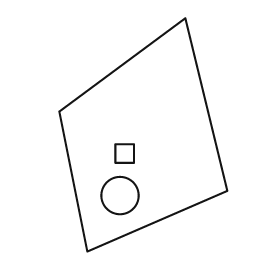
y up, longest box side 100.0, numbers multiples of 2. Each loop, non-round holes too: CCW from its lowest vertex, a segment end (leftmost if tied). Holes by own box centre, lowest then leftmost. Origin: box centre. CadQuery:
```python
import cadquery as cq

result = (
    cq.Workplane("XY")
    .moveTo(-24.0, -50.0)
    .lineTo(36.0, -24.0)
    .lineTo(18.0, 50.0)
    .lineTo(-36.0, 10.0)
    .close()
    .moveTo(-10.0, -26.0)
    .circle(8.0)
    .moveTo(-12.0, -12.0)
    .lineTo(-4.0, -12.0)
    .lineTo(-4.0, -4.0)
    .lineTo(-12.0, -4.0)
    .close()
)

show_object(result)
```